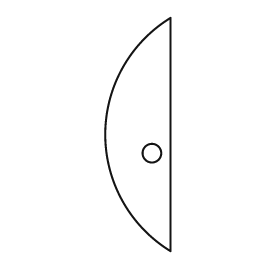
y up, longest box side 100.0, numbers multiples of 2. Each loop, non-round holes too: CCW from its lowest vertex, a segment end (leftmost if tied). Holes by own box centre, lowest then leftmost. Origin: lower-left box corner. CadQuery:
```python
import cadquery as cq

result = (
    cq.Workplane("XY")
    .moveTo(28.0, 0.0)
    .lineTo(28.0, 100.0)
    .threePointArc((0.0, 50.0), (28.0, 0.0))
    .close()
    .moveTo(20.0, 42.0)
    .circle(4.0)
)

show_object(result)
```